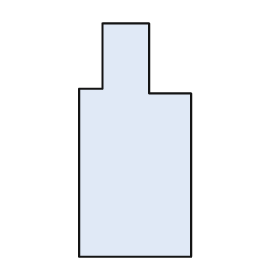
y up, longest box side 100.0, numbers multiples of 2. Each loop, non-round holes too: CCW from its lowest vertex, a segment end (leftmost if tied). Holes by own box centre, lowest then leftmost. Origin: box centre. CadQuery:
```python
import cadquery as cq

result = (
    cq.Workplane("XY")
    .moveTo(-24.0, -50.0)
    .lineTo(24.0, -50.0)
    .lineTo(24.0, 20.0)
    .lineTo(6.0, 20.0)
    .lineTo(6.0, 50.0)
    .lineTo(-14.0, 50.0)
    .lineTo(-14.0, 22.0)
    .lineTo(-24.0, 22.0)
    .close()
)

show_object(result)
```